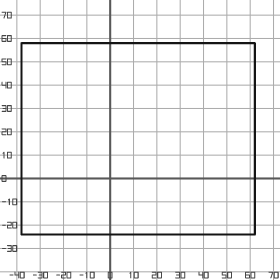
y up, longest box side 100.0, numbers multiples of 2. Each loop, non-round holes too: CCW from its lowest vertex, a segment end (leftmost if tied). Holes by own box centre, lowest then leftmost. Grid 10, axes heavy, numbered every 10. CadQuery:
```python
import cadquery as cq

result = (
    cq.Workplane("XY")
    .moveTo(-38.0, -24.0)
    .lineTo(62.0, -24.0)
    .lineTo(62.0, 58.0)
    .lineTo(-38.0, 58.0)
    .close()
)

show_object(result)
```